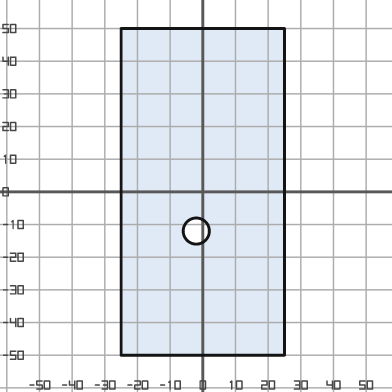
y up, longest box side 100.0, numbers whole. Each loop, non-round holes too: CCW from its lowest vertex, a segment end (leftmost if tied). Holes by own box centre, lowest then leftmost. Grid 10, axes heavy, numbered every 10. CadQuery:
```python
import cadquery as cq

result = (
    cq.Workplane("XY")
    .moveTo(-25.0, -50.0)
    .lineTo(25.0, -50.0)
    .lineTo(25.0, 50.0)
    .lineTo(-25.0, 50.0)
    .close()
    .moveTo(-2.0, -12.0)
    .circle(4.0)
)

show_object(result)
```